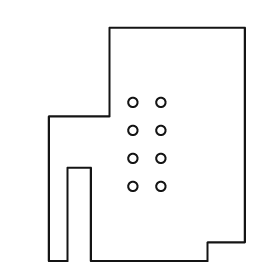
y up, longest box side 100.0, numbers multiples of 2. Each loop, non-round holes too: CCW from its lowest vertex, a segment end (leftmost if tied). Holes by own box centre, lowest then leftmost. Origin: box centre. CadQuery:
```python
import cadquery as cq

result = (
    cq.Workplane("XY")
    .moveTo(-42.0, -50.0)
    .lineTo(-34.0, -50.0)
    .lineTo(-34.0, -10.0)
    .lineTo(-24.0, -10.0)
    .lineTo(-24.0, -50.0)
    .lineTo(26.0, -50.0)
    .lineTo(26.0, -42.0)
    .lineTo(42.0, -42.0)
    .lineTo(42.0, 50.0)
    .lineTo(-16.0, 50.0)
    .lineTo(-16.0, 12.0)
    .lineTo(-42.0, 12.0)
    .close()
    .moveTo(-6.0, -18.0)
    .circle(2.0)
    .moveTo(6.0, -18.0)
    .circle(2.0)
    .moveTo(-6.0, -6.0)
    .circle(2.0)
    .moveTo(6.0, -6.0)
    .circle(2.0)
    .moveTo(-6.0, 6.0)
    .circle(2.0)
    .moveTo(6.0, 6.0)
    .circle(2.0)
    .moveTo(-6.0, 18.0)
    .circle(2.0)
    .moveTo(6.0, 18.0)
    .circle(2.0)
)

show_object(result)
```